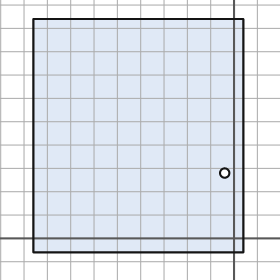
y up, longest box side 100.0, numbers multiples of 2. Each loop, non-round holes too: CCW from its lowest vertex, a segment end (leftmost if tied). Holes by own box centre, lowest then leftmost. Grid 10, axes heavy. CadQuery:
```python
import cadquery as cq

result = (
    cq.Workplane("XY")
    .moveTo(-86.0, -6.0)
    .lineTo(4.0, -6.0)
    .lineTo(4.0, 94.0)
    .lineTo(-86.0, 94.0)
    .close()
    .moveTo(-4.0, 28.0)
    .circle(2.0)
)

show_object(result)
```